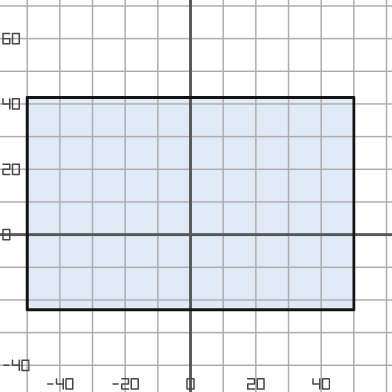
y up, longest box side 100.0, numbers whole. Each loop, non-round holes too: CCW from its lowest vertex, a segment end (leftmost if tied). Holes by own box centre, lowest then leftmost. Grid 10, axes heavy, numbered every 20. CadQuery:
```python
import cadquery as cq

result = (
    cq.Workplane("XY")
    .moveTo(-50.0, -23.0)
    .lineTo(50.0, -23.0)
    .lineTo(50.0, 42.0)
    .lineTo(-50.0, 42.0)
    .close()
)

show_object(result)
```